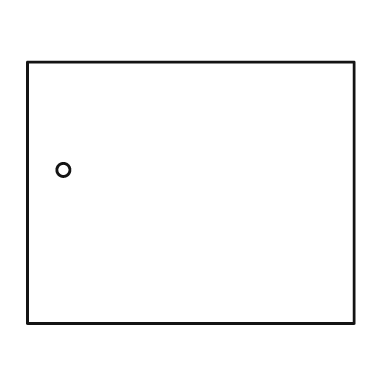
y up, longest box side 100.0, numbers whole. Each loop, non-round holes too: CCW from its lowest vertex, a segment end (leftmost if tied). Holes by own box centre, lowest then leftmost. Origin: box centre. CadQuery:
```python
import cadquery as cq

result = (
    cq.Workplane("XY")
    .moveTo(-50.0, -40.0)
    .lineTo(50.0, -40.0)
    .lineTo(50.0, 40.0)
    .lineTo(-50.0, 40.0)
    .close()
    .moveTo(-39.0, 7.0)
    .circle(2.0)
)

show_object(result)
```